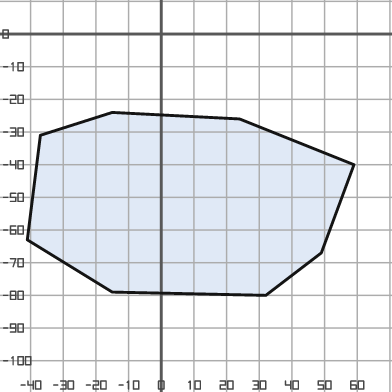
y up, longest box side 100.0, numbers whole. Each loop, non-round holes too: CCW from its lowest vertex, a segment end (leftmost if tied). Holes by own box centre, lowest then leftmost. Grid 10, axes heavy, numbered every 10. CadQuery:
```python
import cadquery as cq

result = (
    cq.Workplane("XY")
    .moveTo(32.0, -80.0)
    .lineTo(49.0, -67.0)
    .lineTo(59.0, -40.0)
    .lineTo(24.0, -26.0)
    .lineTo(-15.0, -24.0)
    .lineTo(-37.0, -31.0)
    .lineTo(-41.0, -63.0)
    .lineTo(-15.0, -79.0)
    .close()
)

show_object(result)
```